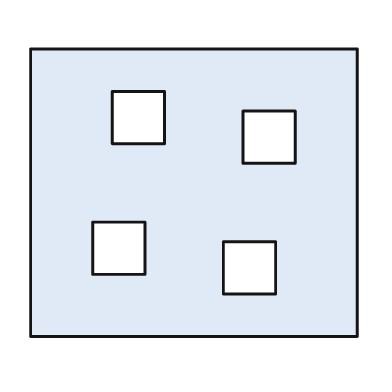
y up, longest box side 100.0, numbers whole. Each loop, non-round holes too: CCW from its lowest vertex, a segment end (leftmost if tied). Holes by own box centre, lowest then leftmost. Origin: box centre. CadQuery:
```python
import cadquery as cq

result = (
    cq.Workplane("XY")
    .moveTo(-50.0, -44.0)
    .lineTo(50.0, -44.0)
    .lineTo(50.0, 44.0)
    .lineTo(-50.0, 44.0)
    .close()
    .moveTo(9.0, -31.0)
    .lineTo(25.0, -31.0)
    .lineTo(25.0, -15.0)
    .lineTo(9.0, -15.0)
    .close()
    .moveTo(-31.0, -25.0)
    .lineTo(-15.0, -25.0)
    .lineTo(-15.0, -9.0)
    .lineTo(-31.0, -9.0)
    .close()
    .moveTo(15.0, 9.0)
    .lineTo(31.0, 9.0)
    .lineTo(31.0, 25.0)
    .lineTo(15.0, 25.0)
    .close()
    .moveTo(-25.0, 15.0)
    .lineTo(-9.0, 15.0)
    .lineTo(-9.0, 31.0)
    .lineTo(-25.0, 31.0)
    .close()
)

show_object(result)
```